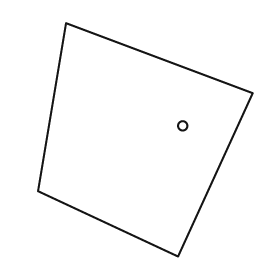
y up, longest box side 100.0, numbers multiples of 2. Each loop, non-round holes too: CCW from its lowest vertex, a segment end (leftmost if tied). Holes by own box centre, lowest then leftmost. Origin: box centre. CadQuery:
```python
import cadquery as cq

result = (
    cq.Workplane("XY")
    .moveTo(14.0, -50.0)
    .lineTo(46.0, 20.0)
    .lineTo(-34.0, 50.0)
    .lineTo(-46.0, -22.0)
    .close()
    .moveTo(16.0, 6.0)
    .circle(2.0)
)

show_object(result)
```